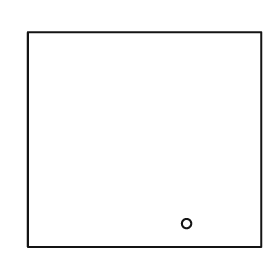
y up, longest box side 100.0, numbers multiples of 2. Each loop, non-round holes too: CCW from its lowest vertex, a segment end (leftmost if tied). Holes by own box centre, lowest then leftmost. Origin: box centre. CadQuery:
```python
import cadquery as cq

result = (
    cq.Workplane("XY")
    .moveTo(-50.0, -46.0)
    .lineTo(50.0, -46.0)
    .lineTo(50.0, 46.0)
    .lineTo(-50.0, 46.0)
    .close()
    .moveTo(18.0, -36.0)
    .circle(2.0)
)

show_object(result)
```